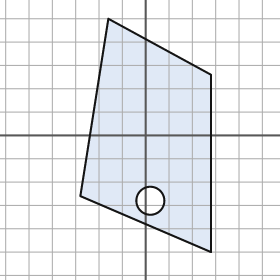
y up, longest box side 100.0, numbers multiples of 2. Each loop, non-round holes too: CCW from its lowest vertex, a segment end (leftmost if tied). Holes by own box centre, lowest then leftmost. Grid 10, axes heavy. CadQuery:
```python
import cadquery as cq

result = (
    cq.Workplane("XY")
    .moveTo(28.0, -50.0)
    .lineTo(28.0, 26.0)
    .lineTo(-16.0, 50.0)
    .lineTo(-28.0, -26.0)
    .close()
    .moveTo(2.0, -28.0)
    .circle(6.0)
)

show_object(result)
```